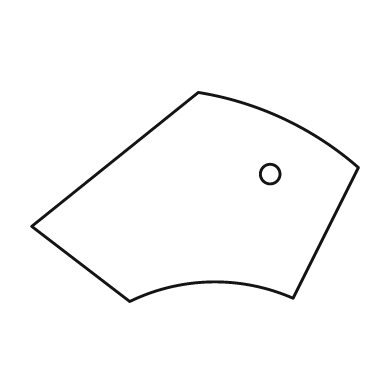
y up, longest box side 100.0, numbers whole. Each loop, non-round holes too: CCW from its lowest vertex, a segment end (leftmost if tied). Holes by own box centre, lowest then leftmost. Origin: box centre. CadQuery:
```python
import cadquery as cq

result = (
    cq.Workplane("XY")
    .moveTo(-20.0, -32.0)
    .threePointArc((5.0, -26.0), (30.0, -31.0))
    .lineTo(50.0, 9.0)
    .threePointArc((27.0, 24.0), (1.0, 32.0))
    .lineTo(-50.0, -9.0)
    .close()
    .moveTo(23.0, 7.0)
    .circle(3.0)
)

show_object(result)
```